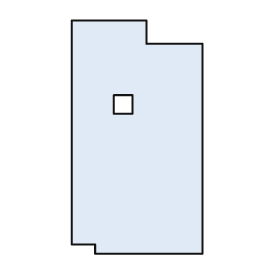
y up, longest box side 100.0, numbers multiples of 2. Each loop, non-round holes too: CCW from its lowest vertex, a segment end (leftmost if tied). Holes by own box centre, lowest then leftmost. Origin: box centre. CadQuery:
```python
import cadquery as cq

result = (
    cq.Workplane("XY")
    .moveTo(-18.0, -50.0)
    .lineTo(28.0, -50.0)
    .lineTo(28.0, 40.0)
    .lineTo(4.0, 40.0)
    .lineTo(4.0, 50.0)
    .lineTo(-28.0, 50.0)
    .lineTo(-28.0, -46.0)
    .lineTo(-18.0, -46.0)
    .close()
    .moveTo(-10.0, 10.0)
    .lineTo(-2.0, 10.0)
    .lineTo(-2.0, 18.0)
    .lineTo(-10.0, 18.0)
    .close()
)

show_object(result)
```